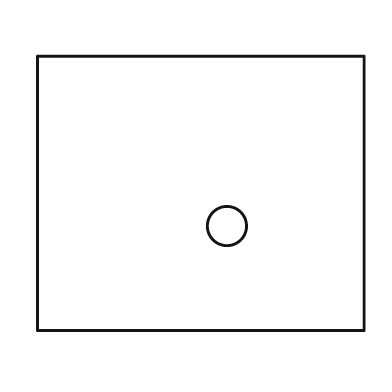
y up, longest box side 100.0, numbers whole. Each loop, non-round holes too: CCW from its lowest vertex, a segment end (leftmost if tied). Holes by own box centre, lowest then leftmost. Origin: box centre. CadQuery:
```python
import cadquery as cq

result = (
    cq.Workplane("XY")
    .moveTo(-50.0, -42.0)
    .lineTo(50.0, -42.0)
    .lineTo(50.0, 42.0)
    .lineTo(-50.0, 42.0)
    .close()
    .moveTo(8.0, -10.0)
    .circle(6.0)
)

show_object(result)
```